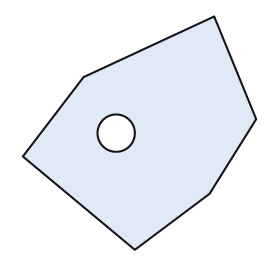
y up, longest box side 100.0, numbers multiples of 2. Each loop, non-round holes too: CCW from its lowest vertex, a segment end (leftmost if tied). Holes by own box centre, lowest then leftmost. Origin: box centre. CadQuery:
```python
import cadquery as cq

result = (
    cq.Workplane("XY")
    .moveTo(-2.0, -50.0)
    .lineTo(30.0, -26.0)
    .lineTo(50.0, 6.0)
    .lineTo(32.0, 50.0)
    .lineTo(-24.0, 24.0)
    .lineTo(-50.0, -10.0)
    .close()
    .moveTo(-10.0, 0.0)
    .circle(8.0)
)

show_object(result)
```